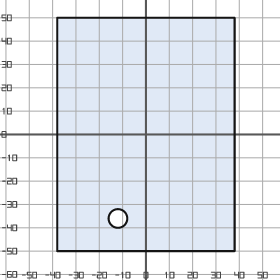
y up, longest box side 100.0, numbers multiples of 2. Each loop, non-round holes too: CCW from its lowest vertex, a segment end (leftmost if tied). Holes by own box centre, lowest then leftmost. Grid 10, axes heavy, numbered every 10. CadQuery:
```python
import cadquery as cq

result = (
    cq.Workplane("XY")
    .moveTo(-38.0, -50.0)
    .lineTo(38.0, -50.0)
    .lineTo(38.0, 50.0)
    .lineTo(-38.0, 50.0)
    .close()
    .moveTo(-12.0, -36.0)
    .circle(4.0)
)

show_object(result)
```